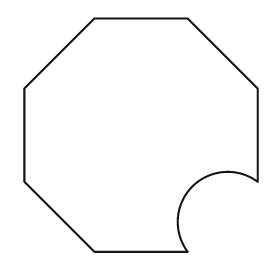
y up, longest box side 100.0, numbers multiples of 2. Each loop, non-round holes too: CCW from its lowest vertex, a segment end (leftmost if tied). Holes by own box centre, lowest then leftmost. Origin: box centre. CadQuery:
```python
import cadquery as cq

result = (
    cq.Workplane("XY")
    .moveTo(-20.0, -50.0)
    .lineTo(20.0, -50.0)
    .threePointArc((22.0, -22.0), (50.0, -20.0))
    .lineTo(50.0, 20.0)
    .lineTo(20.0, 50.0)
    .lineTo(-20.0, 50.0)
    .lineTo(-50.0, 20.0)
    .lineTo(-50.0, -20.0)
    .close()
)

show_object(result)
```